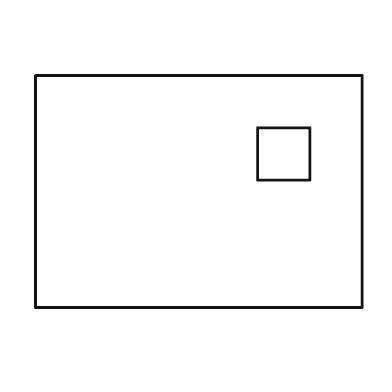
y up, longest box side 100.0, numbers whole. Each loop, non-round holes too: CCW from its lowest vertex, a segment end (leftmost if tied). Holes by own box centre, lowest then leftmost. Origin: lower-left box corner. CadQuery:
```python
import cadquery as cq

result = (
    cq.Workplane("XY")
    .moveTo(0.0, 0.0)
    .lineTo(100.0, 0.0)
    .lineTo(100.0, 71.0)
    .lineTo(0.0, 71.0)
    .close()
    .moveTo(68.0, 39.0)
    .lineTo(84.0, 39.0)
    .lineTo(84.0, 55.0)
    .lineTo(68.0, 55.0)
    .close()
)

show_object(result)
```